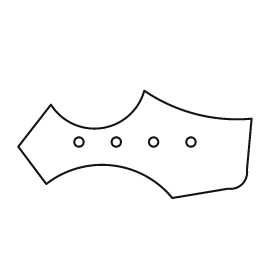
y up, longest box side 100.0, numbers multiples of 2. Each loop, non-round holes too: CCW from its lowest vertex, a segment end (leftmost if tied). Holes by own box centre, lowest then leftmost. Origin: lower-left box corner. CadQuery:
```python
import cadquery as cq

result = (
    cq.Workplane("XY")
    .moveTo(66.0, 0.0)
    .lineTo(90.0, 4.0)
    .threePointArc((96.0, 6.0), (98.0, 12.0))
    .lineTo(100.0, 34.0)
    .threePointArc((76.0, 36.0), (54.0, 46.0))
    .threePointArc((36.0, 30.0), (14.0, 40.0))
    .lineTo(0.0, 22.0)
    .lineTo(12.0, 6.0)
    .threePointArc((40.0, 14.0), (66.0, 0.0))
    .close()
    .moveTo(26.0, 24.0)
    .circle(2.0)
    .moveTo(42.0, 24.0)
    .circle(2.0)
    .moveTo(58.0, 24.0)
    .circle(2.0)
    .moveTo(74.0, 24.0)
    .circle(2.0)
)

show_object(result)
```